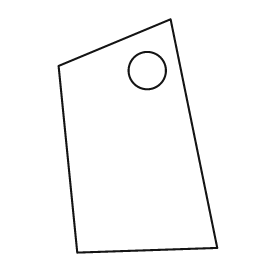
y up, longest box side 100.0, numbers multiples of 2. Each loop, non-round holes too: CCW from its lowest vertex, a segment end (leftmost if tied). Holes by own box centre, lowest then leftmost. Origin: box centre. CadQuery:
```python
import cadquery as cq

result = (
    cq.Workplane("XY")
    .moveTo(-26.0, -50.0)
    .lineTo(34.0, -48.0)
    .lineTo(14.0, 50.0)
    .lineTo(-34.0, 30.0)
    .close()
    .moveTo(4.0, 28.0)
    .circle(8.0)
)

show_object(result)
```